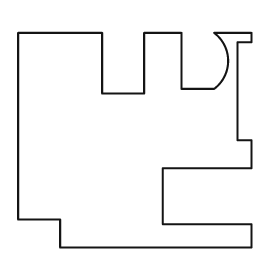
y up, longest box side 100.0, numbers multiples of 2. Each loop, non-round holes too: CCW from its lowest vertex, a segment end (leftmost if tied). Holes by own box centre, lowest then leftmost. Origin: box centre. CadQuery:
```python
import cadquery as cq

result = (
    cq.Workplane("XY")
    .moveTo(-32.0, -46.0)
    .lineTo(50.0, -46.0)
    .lineTo(50.0, -36.0)
    .lineTo(12.0, -36.0)
    .lineTo(12.0, -12.0)
    .lineTo(50.0, -12.0)
    .lineTo(50.0, 0.0)
    .lineTo(44.0, 0.0)
    .lineTo(44.0, 42.0)
    .lineTo(50.0, 42.0)
    .lineTo(50.0, 46.0)
    .lineTo(34.0, 46.0)
    .threePointArc((40.0, 34.0), (34.0, 22.0))
    .lineTo(20.0, 22.0)
    .lineTo(20.0, 46.0)
    .lineTo(4.0, 46.0)
    .lineTo(4.0, 20.0)
    .lineTo(-14.0, 20.0)
    .lineTo(-14.0, 46.0)
    .lineTo(-50.0, 46.0)
    .lineTo(-50.0, -34.0)
    .lineTo(-32.0, -34.0)
    .close()
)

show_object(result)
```